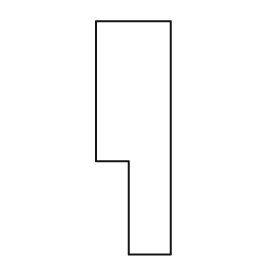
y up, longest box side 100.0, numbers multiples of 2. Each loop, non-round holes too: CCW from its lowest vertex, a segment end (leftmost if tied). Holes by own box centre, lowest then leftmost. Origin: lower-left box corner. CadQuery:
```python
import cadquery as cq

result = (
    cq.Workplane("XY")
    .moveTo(14.0, 0.0)
    .lineTo(32.0, 0.0)
    .lineTo(32.0, 100.0)
    .lineTo(0.0, 100.0)
    .lineTo(0.0, 40.0)
    .lineTo(14.0, 40.0)
    .close()
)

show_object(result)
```